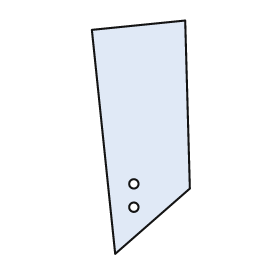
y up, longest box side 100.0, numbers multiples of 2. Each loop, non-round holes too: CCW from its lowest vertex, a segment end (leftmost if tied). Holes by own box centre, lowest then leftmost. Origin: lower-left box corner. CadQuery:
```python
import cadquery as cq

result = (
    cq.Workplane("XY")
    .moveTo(10.0, 0.0)
    .lineTo(42.0, 28.0)
    .lineTo(40.0, 100.0)
    .lineTo(0.0, 96.0)
    .close()
    .moveTo(18.0, 20.0)
    .circle(2.0)
    .moveTo(18.0, 30.0)
    .circle(2.0)
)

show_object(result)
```